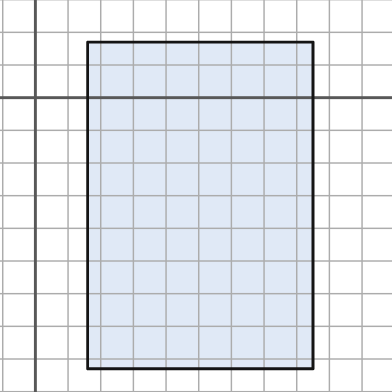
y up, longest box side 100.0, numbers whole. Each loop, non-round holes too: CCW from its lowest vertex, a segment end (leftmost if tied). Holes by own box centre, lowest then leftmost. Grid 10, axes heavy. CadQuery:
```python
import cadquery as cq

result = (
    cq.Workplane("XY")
    .moveTo(16.0, -83.0)
    .lineTo(85.0, -83.0)
    .lineTo(85.0, 17.0)
    .lineTo(16.0, 17.0)
    .close()
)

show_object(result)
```